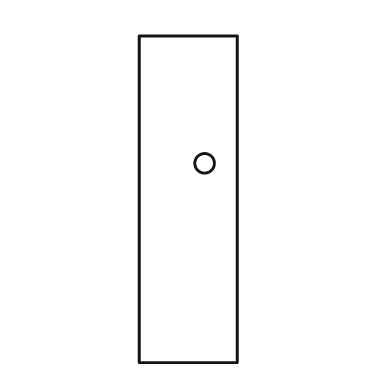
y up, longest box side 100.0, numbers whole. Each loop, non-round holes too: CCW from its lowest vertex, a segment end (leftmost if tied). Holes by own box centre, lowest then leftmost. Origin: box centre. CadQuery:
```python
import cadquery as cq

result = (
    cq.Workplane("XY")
    .moveTo(-15.0, -50.0)
    .lineTo(15.0, -50.0)
    .lineTo(15.0, 50.0)
    .lineTo(-15.0, 50.0)
    .close()
    .moveTo(5.0, 11.0)
    .circle(3.0)
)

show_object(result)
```